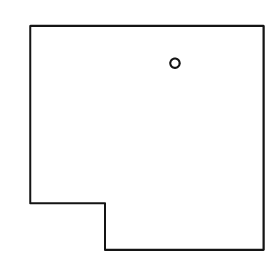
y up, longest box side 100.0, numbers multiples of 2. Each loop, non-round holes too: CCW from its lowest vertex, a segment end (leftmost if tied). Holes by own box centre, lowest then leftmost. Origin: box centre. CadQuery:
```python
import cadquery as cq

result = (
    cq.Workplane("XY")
    .moveTo(-18.0, -48.0)
    .lineTo(50.0, -48.0)
    .lineTo(50.0, 48.0)
    .lineTo(-50.0, 48.0)
    .lineTo(-50.0, -28.0)
    .lineTo(-18.0, -28.0)
    .close()
    .moveTo(12.0, 32.0)
    .circle(2.0)
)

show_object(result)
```